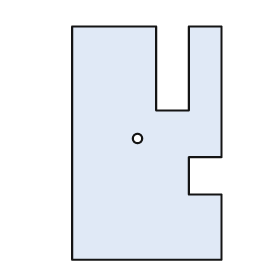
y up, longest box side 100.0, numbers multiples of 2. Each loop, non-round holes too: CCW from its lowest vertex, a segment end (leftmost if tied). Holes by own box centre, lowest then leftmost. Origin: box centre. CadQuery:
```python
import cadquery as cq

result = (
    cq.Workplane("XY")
    .moveTo(-32.0, -50.0)
    .lineTo(32.0, -50.0)
    .lineTo(32.0, -22.0)
    .lineTo(18.0, -22.0)
    .lineTo(18.0, -6.0)
    .lineTo(32.0, -6.0)
    .lineTo(32.0, 50.0)
    .lineTo(18.0, 50.0)
    .lineTo(18.0, 14.0)
    .lineTo(4.0, 14.0)
    .lineTo(4.0, 50.0)
    .lineTo(-32.0, 50.0)
    .close()
    .moveTo(-4.0, 2.0)
    .circle(2.0)
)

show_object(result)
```